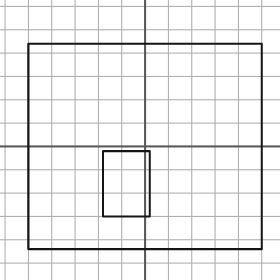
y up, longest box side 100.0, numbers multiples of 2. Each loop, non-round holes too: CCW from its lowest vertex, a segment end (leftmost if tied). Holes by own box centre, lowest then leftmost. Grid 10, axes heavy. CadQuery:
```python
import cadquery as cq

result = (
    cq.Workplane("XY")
    .moveTo(-50.0, -44.0)
    .lineTo(50.0, -44.0)
    .lineTo(50.0, 44.0)
    .lineTo(-50.0, 44.0)
    .close()
    .moveTo(-18.0, -30.0)
    .lineTo(2.0, -30.0)
    .lineTo(2.0, -2.0)
    .lineTo(-18.0, -2.0)
    .close()
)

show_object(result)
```